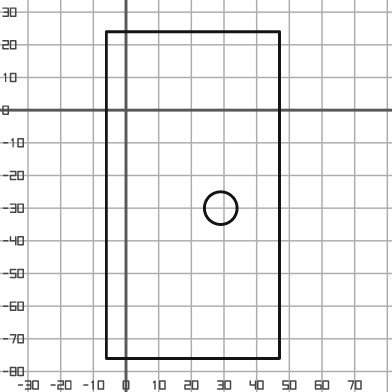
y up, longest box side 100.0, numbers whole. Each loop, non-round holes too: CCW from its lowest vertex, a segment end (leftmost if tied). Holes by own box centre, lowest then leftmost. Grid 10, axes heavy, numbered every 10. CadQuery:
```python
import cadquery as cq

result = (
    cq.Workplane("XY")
    .moveTo(-6.0, -76.0)
    .lineTo(47.0, -76.0)
    .lineTo(47.0, 24.0)
    .lineTo(-6.0, 24.0)
    .close()
    .moveTo(29.0, -30.0)
    .circle(5.0)
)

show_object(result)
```